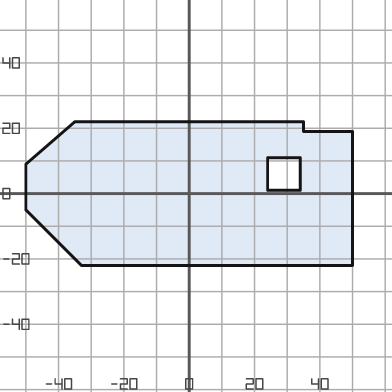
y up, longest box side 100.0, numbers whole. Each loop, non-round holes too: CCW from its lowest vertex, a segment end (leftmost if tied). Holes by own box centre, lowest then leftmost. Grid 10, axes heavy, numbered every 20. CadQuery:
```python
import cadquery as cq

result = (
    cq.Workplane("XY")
    .moveTo(-33.0, -22.0)
    .lineTo(50.0, -22.0)
    .lineTo(50.0, 19.0)
    .lineTo(35.0, 19.0)
    .lineTo(35.0, 22.0)
    .lineTo(-35.0, 22.0)
    .lineTo(-50.0, 9.0)
    .lineTo(-50.0, -5.0)
    .close()
    .moveTo(24.0, 1.0)
    .lineTo(34.0, 1.0)
    .lineTo(34.0, 11.0)
    .lineTo(24.0, 11.0)
    .close()
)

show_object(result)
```